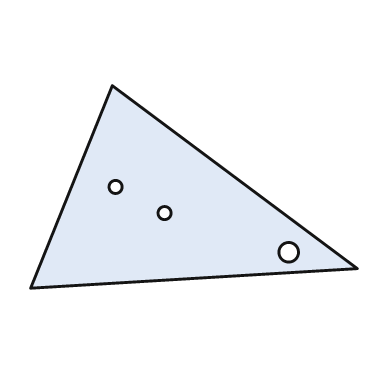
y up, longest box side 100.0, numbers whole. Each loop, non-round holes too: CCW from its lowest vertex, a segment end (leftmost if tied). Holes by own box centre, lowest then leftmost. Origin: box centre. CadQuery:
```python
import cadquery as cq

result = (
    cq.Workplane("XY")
    .moveTo(-50.0, -31.0)
    .lineTo(50.0, -25.0)
    .lineTo(-25.0, 31.0)
    .close()
    .moveTo(29.0, -20.0)
    .circle(3.0)
    .moveTo(-9.0, -8.0)
    .circle(2.0)
    .moveTo(-24.0, 0.0)
    .circle(2.0)
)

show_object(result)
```